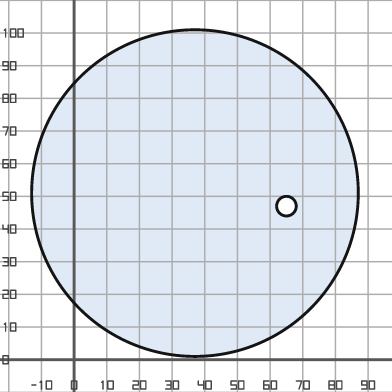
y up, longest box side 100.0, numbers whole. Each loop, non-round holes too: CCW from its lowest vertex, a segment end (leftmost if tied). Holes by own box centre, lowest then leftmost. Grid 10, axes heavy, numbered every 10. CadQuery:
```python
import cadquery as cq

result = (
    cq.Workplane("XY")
    .moveTo(37.0, 51.0)
    .circle(50.0)
    .moveTo(65.0, 47.0)
    .circle(3.0)
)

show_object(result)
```